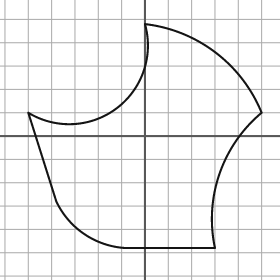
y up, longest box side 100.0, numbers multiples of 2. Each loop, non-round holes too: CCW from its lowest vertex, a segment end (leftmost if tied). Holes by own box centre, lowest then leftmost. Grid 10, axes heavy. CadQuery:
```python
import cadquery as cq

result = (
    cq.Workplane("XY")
    .moveTo(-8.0, -48.0)
    .lineTo(30.0, -48.0)
    .threePointArc((32.0, -16.0), (50.0, 10.0))
    .threePointArc((30.0, 36.0), (0.0, 48.0))
    .threePointArc((-12.0, 12.0), (-50.0, 10.0))
    .lineTo(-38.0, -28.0)
    .threePointArc((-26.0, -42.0), (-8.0, -48.0))
    .close()
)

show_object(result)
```